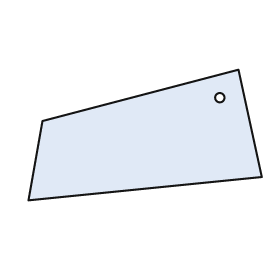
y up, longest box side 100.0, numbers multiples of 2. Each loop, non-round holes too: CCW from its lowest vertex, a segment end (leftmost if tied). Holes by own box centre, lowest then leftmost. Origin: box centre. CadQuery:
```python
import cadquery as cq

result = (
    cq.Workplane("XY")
    .moveTo(-50.0, -28.0)
    .lineTo(50.0, -18.0)
    .lineTo(40.0, 28.0)
    .lineTo(-44.0, 6.0)
    .close()
    .moveTo(32.0, 16.0)
    .circle(2.0)
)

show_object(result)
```